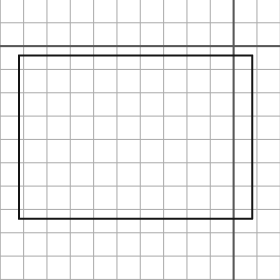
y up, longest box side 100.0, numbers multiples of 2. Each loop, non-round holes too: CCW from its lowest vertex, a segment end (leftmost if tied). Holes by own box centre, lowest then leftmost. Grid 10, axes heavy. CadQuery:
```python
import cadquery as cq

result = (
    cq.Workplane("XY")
    .moveTo(-92.0, -74.0)
    .lineTo(8.0, -74.0)
    .lineTo(8.0, -4.0)
    .lineTo(-92.0, -4.0)
    .close()
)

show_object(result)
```